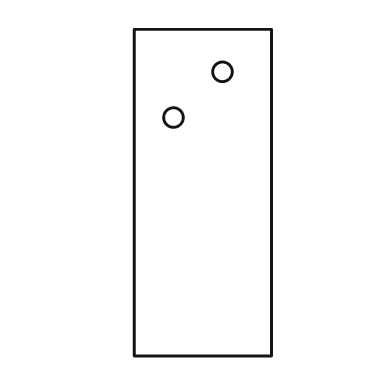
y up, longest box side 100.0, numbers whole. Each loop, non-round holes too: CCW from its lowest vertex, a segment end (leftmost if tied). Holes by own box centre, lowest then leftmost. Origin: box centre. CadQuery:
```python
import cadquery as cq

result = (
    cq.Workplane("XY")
    .moveTo(-21.0, -50.0)
    .lineTo(21.0, -50.0)
    .lineTo(21.0, 50.0)
    .lineTo(-21.0, 50.0)
    .close()
    .moveTo(-9.0, 23.0)
    .circle(3.0)
    .moveTo(6.0, 37.0)
    .circle(3.0)
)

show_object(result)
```